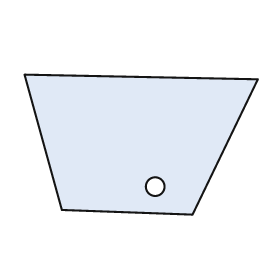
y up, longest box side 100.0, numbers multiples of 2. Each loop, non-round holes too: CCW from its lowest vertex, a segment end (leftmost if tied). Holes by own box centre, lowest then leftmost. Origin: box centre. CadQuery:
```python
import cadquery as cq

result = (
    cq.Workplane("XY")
    .moveTo(22.0, -30.0)
    .lineTo(50.0, 28.0)
    .lineTo(-50.0, 30.0)
    .lineTo(-34.0, -28.0)
    .close()
    .moveTo(6.0, -18.0)
    .circle(4.0)
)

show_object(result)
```